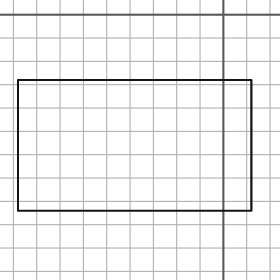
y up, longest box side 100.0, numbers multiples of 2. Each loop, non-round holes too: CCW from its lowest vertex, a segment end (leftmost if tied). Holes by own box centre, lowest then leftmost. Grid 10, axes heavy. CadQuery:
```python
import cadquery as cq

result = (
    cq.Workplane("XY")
    .moveTo(-88.0, -84.0)
    .lineTo(12.0, -84.0)
    .lineTo(12.0, -28.0)
    .lineTo(-88.0, -28.0)
    .close()
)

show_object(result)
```